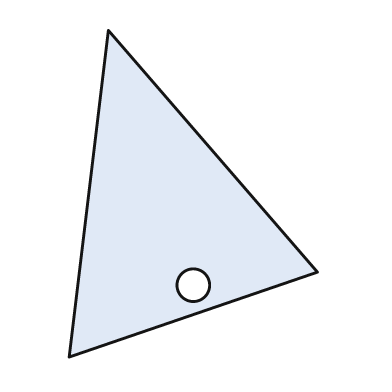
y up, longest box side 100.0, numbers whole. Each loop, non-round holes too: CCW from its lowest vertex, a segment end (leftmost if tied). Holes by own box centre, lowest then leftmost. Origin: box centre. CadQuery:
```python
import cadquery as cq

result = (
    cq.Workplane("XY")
    .moveTo(-38.0, -50.0)
    .lineTo(38.0, -24.0)
    .lineTo(-26.0, 50.0)
    .close()
    .moveTo(0.0, -28.0)
    .circle(5.0)
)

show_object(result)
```